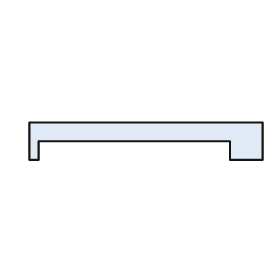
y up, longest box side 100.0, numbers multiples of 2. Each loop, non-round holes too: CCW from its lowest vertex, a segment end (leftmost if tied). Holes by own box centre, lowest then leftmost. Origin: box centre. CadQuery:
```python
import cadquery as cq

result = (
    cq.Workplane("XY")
    .moveTo(-50.0, -8.0)
    .lineTo(-46.0, -8.0)
    .lineTo(-46.0, 0.0)
    .lineTo(36.0, 0.0)
    .lineTo(36.0, -8.0)
    .lineTo(50.0, -8.0)
    .lineTo(50.0, 8.0)
    .lineTo(-50.0, 8.0)
    .close()
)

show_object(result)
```